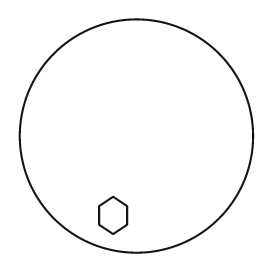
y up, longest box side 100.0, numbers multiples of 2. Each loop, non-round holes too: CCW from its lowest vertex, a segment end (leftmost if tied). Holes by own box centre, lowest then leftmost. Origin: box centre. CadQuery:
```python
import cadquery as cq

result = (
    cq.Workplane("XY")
    .moveTo(0.0, 0.0)
    .circle(50.0)
    .moveTo(-10.0, -42.0)
    .lineTo(-4.0, -38.0)
    .lineTo(-4.0, -30.0)
    .lineTo(-10.0, -26.0)
    .lineTo(-16.0, -30.0)
    .lineTo(-16.0, -38.0)
    .close()
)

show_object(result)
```